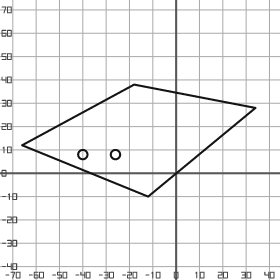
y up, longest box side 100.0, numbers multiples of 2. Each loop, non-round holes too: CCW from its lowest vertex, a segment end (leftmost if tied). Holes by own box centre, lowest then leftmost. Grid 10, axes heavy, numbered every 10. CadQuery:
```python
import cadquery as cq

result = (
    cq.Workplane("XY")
    .moveTo(-12.0, -10.0)
    .lineTo(34.0, 28.0)
    .lineTo(-18.0, 38.0)
    .lineTo(-66.0, 12.0)
    .close()
    .moveTo(-40.0, 8.0)
    .circle(2.0)
    .moveTo(-26.0, 8.0)
    .circle(2.0)
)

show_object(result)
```